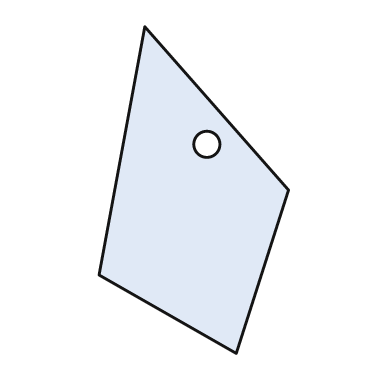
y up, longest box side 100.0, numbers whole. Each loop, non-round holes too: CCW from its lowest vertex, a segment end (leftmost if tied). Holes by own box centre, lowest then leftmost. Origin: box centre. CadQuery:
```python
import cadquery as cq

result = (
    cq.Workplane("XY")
    .moveTo(13.0, -50.0)
    .lineTo(29.0, 0.0)
    .lineTo(-15.0, 50.0)
    .lineTo(-29.0, -26.0)
    .close()
    .moveTo(4.0, 14.0)
    .circle(4.0)
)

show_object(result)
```